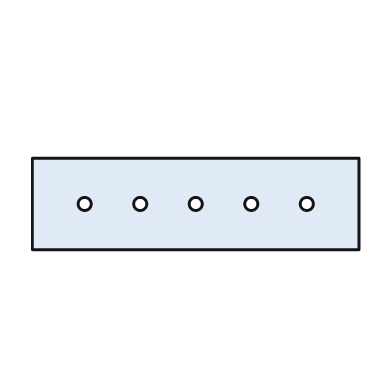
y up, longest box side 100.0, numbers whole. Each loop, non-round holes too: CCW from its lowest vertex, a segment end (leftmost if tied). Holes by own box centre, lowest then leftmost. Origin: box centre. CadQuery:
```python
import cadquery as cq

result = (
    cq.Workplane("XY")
    .moveTo(-50.0, -14.0)
    .lineTo(50.0, -14.0)
    .lineTo(50.0, 14.0)
    .lineTo(-50.0, 14.0)
    .close()
    .moveTo(-34.0, 0.0)
    .circle(2.0)
    .moveTo(-17.0, 0.0)
    .circle(2.0)
    .moveTo(0.0, 0.0)
    .circle(2.0)
    .moveTo(17.0, 0.0)
    .circle(2.0)
    .moveTo(34.0, 0.0)
    .circle(2.0)
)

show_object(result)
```